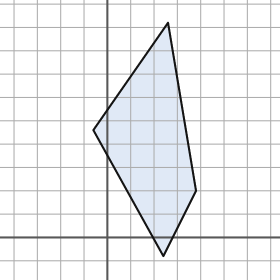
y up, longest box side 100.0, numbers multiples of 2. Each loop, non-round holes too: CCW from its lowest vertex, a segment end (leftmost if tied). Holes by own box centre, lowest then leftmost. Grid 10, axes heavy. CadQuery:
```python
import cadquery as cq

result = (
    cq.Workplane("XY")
    .moveTo(24.0, -8.0)
    .lineTo(38.0, 20.0)
    .lineTo(26.0, 92.0)
    .lineTo(-6.0, 46.0)
    .close()
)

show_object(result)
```